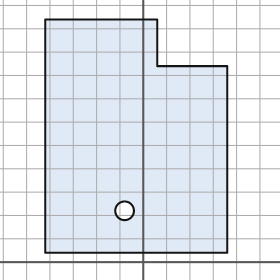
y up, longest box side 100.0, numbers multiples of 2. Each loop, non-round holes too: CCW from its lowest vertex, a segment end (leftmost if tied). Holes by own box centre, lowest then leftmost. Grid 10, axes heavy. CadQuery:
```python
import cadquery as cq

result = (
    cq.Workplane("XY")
    .moveTo(-42.0, 4.0)
    .lineTo(36.0, 4.0)
    .lineTo(36.0, 84.0)
    .lineTo(6.0, 84.0)
    .lineTo(6.0, 104.0)
    .lineTo(-42.0, 104.0)
    .close()
    .moveTo(-8.0, 22.0)
    .circle(4.0)
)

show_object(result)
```